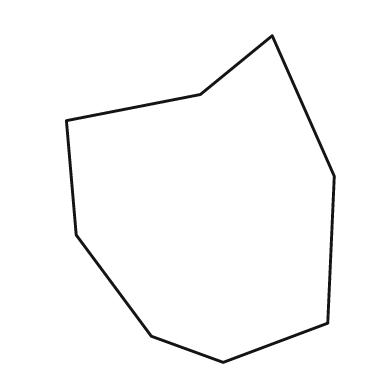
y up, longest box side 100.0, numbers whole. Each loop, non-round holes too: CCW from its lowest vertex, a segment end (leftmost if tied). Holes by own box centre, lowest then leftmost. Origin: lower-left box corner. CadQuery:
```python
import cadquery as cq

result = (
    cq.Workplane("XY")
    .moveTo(48.0, 0.0)
    .lineTo(80.0, 12.0)
    .lineTo(82.0, 57.0)
    .lineTo(63.0, 100.0)
    .lineTo(41.0, 82.0)
    .lineTo(0.0, 74.0)
    .lineTo(3.0, 39.0)
    .lineTo(26.0, 8.0)
    .close()
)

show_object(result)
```